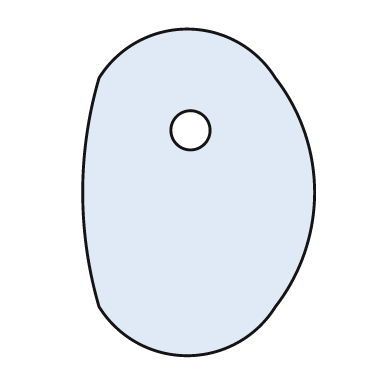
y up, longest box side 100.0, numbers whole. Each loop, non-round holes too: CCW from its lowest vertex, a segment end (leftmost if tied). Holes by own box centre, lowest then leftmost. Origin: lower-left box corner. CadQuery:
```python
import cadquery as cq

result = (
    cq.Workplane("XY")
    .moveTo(5.0, 15.0)
    .threePointArc((32.0, 0.0), (59.0, 15.0))
    .threePointArc((71.0, 50.0), (59.0, 85.0))
    .threePointArc((32.0, 100.0), (5.0, 85.0))
    .threePointArc((0.0, 50.0), (5.0, 15.0))
    .close()
    .moveTo(33.0, 69.0)
    .circle(6.0)
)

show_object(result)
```